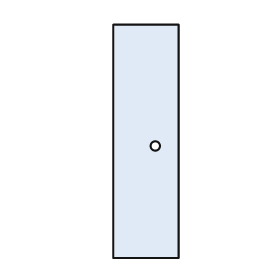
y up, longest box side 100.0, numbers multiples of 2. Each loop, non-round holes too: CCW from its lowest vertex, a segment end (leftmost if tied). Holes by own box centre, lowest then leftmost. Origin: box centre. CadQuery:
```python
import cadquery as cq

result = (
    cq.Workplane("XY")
    .moveTo(-14.0, -50.0)
    .lineTo(14.0, -50.0)
    .lineTo(14.0, 50.0)
    .lineTo(-14.0, 50.0)
    .close()
    .moveTo(4.0, -2.0)
    .circle(2.0)
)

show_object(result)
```